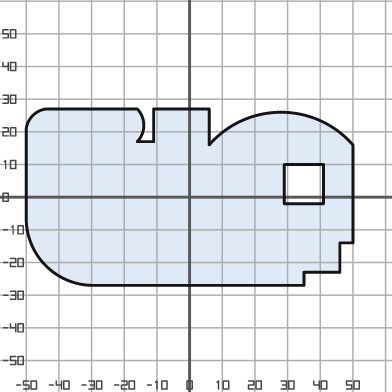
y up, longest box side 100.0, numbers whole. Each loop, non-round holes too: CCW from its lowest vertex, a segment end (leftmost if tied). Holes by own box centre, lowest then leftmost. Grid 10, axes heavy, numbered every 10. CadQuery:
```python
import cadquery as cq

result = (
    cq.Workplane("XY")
    .moveTo(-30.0, -27.0)
    .lineTo(35.0, -27.0)
    .lineTo(35.0, -23.0)
    .lineTo(46.0, -23.0)
    .lineTo(46.0, -14.0)
    .lineTo(50.0, -14.0)
    .lineTo(50.0, 16.0)
    .threePointArc((28.0, 26.0), (6.0, 16.0))
    .lineTo(6.0, 27.0)
    .lineTo(-11.0, 27.0)
    .lineTo(-11.0, 17.0)
    .lineTo(-16.0, 17.0)
    .threePointArc((-14.0, 22.0), (-16.0, 27.0))
    .lineTo(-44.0, 27.0)
    .threePointArc((-48.0, 25.0), (-50.0, 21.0))
    .lineTo(-50.0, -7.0)
    .threePointArc((-44.0, -21.0), (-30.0, -27.0))
    .close()
    .moveTo(29.0, -2.0)
    .lineTo(41.0, -2.0)
    .lineTo(41.0, 10.0)
    .lineTo(29.0, 10.0)
    .close()
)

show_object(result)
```